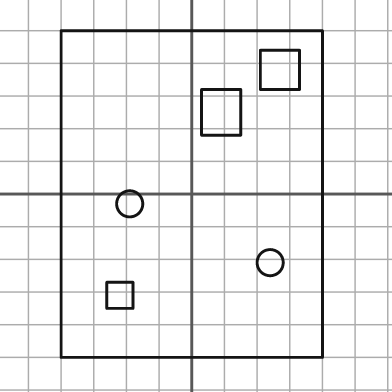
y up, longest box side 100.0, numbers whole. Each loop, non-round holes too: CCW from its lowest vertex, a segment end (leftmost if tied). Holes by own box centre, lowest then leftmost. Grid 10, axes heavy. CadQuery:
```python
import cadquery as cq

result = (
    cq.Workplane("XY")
    .moveTo(-40.0, -50.0)
    .lineTo(40.0, -50.0)
    .lineTo(40.0, 50.0)
    .lineTo(-40.0, 50.0)
    .close()
    .moveTo(-26.0, -35.0)
    .lineTo(-18.0, -35.0)
    .lineTo(-18.0, -27.0)
    .lineTo(-26.0, -27.0)
    .close()
    .moveTo(24.0, -21.0)
    .circle(4.0)
    .moveTo(-19.0, -3.0)
    .circle(4.0)
    .moveTo(3.0, 18.0)
    .lineTo(15.0, 18.0)
    .lineTo(15.0, 32.0)
    .lineTo(3.0, 32.0)
    .close()
    .moveTo(21.0, 32.0)
    .lineTo(33.0, 32.0)
    .lineTo(33.0, 44.0)
    .lineTo(21.0, 44.0)
    .close()
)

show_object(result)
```